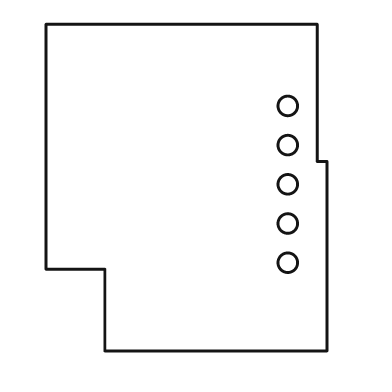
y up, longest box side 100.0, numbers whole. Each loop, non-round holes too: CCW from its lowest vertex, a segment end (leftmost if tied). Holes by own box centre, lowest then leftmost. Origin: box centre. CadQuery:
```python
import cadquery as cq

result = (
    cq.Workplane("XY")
    .moveTo(-25.0, -50.0)
    .lineTo(43.0, -50.0)
    .lineTo(43.0, 8.0)
    .lineTo(40.0, 8.0)
    .lineTo(40.0, 50.0)
    .lineTo(-43.0, 50.0)
    .lineTo(-43.0, -25.0)
    .lineTo(-25.0, -25.0)
    .close()
    .moveTo(31.0, -23.0)
    .circle(3.0)
    .moveTo(31.0, -11.0)
    .circle(3.0)
    .moveTo(31.0, 1.0)
    .circle(3.0)
    .moveTo(31.0, 13.0)
    .circle(3.0)
    .moveTo(31.0, 25.0)
    .circle(3.0)
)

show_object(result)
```